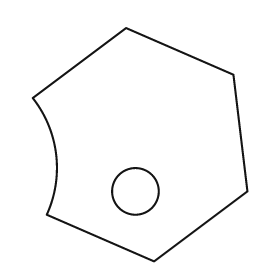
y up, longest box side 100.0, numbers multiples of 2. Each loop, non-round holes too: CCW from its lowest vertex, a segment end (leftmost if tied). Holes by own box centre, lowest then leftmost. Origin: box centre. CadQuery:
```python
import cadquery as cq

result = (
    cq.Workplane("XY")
    .moveTo(6.0, -50.0)
    .lineTo(46.0, -20.0)
    .lineTo(40.0, 30.0)
    .lineTo(-6.0, 50.0)
    .lineTo(-46.0, 20.0)
    .threePointArc((-36.0, -4.0), (-40.0, -30.0))
    .close()
    .moveTo(-2.0, -20.0)
    .circle(10.0)
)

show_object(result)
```